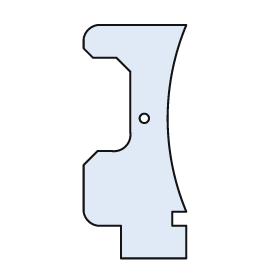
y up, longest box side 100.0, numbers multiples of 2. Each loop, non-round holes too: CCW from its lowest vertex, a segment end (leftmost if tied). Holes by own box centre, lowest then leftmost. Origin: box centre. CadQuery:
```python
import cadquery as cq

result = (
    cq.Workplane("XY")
    .moveTo(-6.0, -50.0)
    .lineTo(22.0, -50.0)
    .lineTo(22.0, -36.0)
    .lineTo(16.0, -36.0)
    .lineTo(16.0, -30.0)
    .lineTo(22.0, -30.0)
    .threePointArc((14.0, 10.0), (22.0, 50.0))
    .lineTo(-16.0, 50.0)
    .threePointArc((-20.0, 48.0), (-22.0, 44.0))
    .lineTo(-22.0, 40.0)
    .lineTo(-18.0, 36.0)
    .lineTo(-8.0, 36.0)
    .lineTo(-2.0, 30.0)
    .lineTo(-2.0, 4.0)
    .threePointArc((-4.0, -2.0), (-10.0, -4.0))
    .lineTo(-16.0, -4.0)
    .lineTo(-22.0, -10.0)
    .lineTo(-22.0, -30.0)
    .threePointArc((-20.0, -34.0), (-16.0, -36.0))
    .lineTo(-6.0, -36.0)
    .close()
    .moveTo(4.0, 10.0)
    .circle(2.0)
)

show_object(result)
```